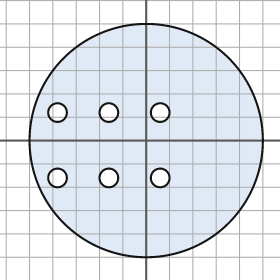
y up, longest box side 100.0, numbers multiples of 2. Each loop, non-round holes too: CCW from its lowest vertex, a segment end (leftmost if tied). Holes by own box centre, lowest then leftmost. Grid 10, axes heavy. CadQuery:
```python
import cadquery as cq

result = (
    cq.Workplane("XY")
    .moveTo(0.0, 0.0)
    .circle(50.0)
    .moveTo(-38.0, -16.0)
    .circle(4.0)
    .moveTo(-16.0, -16.0)
    .circle(4.0)
    .moveTo(6.0, -16.0)
    .circle(4.0)
    .moveTo(-38.0, 12.0)
    .circle(4.0)
    .moveTo(-16.0, 12.0)
    .circle(4.0)
    .moveTo(6.0, 12.0)
    .circle(4.0)
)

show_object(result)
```